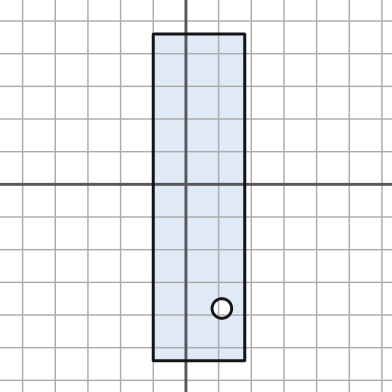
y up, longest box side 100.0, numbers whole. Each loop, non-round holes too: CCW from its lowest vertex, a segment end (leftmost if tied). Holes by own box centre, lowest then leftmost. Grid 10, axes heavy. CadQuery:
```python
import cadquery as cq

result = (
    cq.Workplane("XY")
    .moveTo(-10.0, -54.0)
    .lineTo(18.0, -54.0)
    .lineTo(18.0, 46.0)
    .lineTo(-10.0, 46.0)
    .close()
    .moveTo(11.0, -38.0)
    .circle(3.0)
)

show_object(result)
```